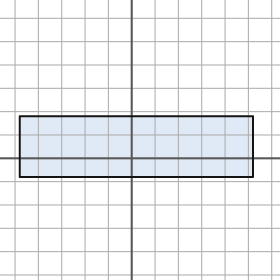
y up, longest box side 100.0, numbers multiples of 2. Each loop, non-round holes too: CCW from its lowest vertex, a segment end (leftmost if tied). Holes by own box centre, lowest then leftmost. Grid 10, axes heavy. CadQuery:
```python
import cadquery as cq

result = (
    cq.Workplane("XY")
    .moveTo(-48.0, -8.0)
    .lineTo(52.0, -8.0)
    .lineTo(52.0, 18.0)
    .lineTo(-48.0, 18.0)
    .close()
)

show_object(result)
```